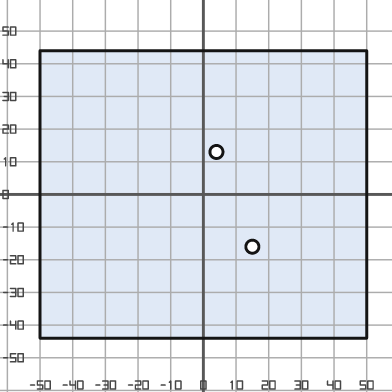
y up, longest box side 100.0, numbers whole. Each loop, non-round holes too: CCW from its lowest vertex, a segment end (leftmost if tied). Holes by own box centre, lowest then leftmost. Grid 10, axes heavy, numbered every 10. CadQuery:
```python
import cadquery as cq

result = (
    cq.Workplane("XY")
    .moveTo(-50.0, -44.0)
    .lineTo(50.0, -44.0)
    .lineTo(50.0, 44.0)
    .lineTo(-50.0, 44.0)
    .close()
    .moveTo(15.0, -16.0)
    .circle(2.0)
    .moveTo(4.0, 13.0)
    .circle(2.0)
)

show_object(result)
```